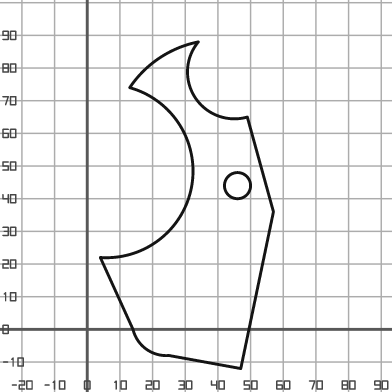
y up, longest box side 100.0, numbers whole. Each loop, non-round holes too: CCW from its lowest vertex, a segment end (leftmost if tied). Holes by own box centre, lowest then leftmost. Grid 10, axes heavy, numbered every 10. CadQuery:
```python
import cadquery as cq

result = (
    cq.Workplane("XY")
    .moveTo(47.0, -12.0)
    .lineTo(57.0, 36.0)
    .lineTo(49.0, 65.0)
    .threePointArc((33.0, 71.0), (34.0, 88.0))
    .threePointArc((22.0, 83.0), (13.0, 74.0))
    .threePointArc((32.0, 44.0), (4.0, 22.0))
    .lineTo(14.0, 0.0)
    .threePointArc((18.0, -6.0), (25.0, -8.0))
    .close()
    .moveTo(46.0, 44.0)
    .circle(4.0)
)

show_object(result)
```